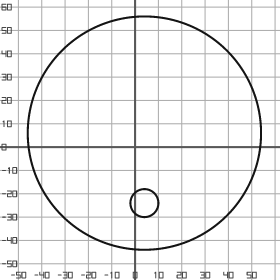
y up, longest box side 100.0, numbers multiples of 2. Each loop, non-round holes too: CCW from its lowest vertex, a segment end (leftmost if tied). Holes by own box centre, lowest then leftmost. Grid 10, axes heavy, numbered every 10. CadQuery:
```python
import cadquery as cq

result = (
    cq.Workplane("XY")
    .moveTo(4.0, 6.0)
    .circle(50.0)
    .moveTo(4.0, -24.0)
    .circle(6.0)
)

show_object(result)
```